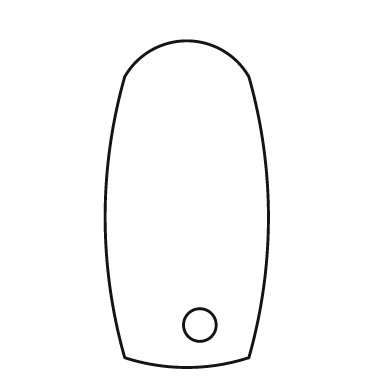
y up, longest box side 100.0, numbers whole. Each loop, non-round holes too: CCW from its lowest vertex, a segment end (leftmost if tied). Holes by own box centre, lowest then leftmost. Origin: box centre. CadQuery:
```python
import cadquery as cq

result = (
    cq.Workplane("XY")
    .moveTo(-19.0, -47.0)
    .threePointArc((0.0, -50.0), (19.0, -47.0))
    .threePointArc((25.0, -4.0), (19.0, 39.0))
    .threePointArc((0.0, 50.0), (-19.0, 39.0))
    .threePointArc((-25.0, -4.0), (-19.0, -47.0))
    .close()
    .moveTo(4.0, -37.0)
    .circle(5.0)
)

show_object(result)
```